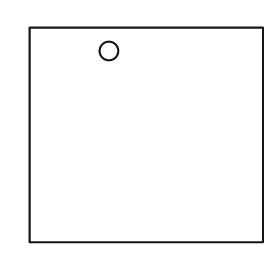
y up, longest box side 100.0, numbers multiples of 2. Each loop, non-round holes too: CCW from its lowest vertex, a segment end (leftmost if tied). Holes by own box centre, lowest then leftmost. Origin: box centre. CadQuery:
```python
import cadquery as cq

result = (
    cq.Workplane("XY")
    .moveTo(-50.0, -46.0)
    .lineTo(50.0, -46.0)
    .lineTo(50.0, 46.0)
    .lineTo(-50.0, 46.0)
    .close()
    .moveTo(-16.0, 36.0)
    .circle(4.0)
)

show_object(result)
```